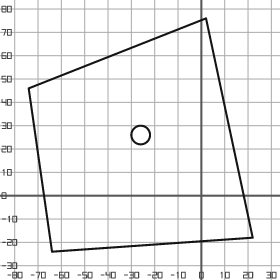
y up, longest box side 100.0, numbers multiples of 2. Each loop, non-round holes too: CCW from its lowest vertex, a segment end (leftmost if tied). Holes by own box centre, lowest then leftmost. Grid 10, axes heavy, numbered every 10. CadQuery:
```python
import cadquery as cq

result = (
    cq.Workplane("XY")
    .moveTo(-64.0, -24.0)
    .lineTo(22.0, -18.0)
    .lineTo(2.0, 76.0)
    .lineTo(-74.0, 46.0)
    .close()
    .moveTo(-26.0, 26.0)
    .circle(4.0)
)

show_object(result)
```